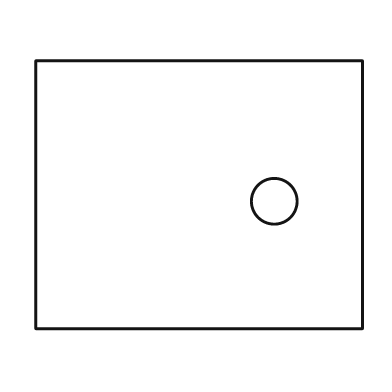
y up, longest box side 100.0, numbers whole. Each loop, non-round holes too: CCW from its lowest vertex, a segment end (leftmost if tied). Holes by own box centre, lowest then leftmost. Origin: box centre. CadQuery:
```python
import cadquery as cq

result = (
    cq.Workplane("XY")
    .moveTo(-50.0, -41.0)
    .lineTo(50.0, -41.0)
    .lineTo(50.0, 41.0)
    .lineTo(-50.0, 41.0)
    .close()
    .moveTo(23.0, -2.0)
    .circle(7.0)
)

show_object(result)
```